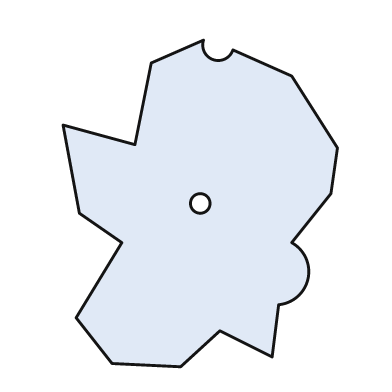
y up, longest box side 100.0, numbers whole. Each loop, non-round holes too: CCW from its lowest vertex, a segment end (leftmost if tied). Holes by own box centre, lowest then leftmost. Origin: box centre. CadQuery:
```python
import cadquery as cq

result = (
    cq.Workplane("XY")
    .moveTo(-6.0, -50.0)
    .lineTo(6.0, -39.0)
    .lineTo(22.0, -47.0)
    .lineTo(24.0, -31.0)
    .threePointArc((33.0, -23.0), (28.0, -12.0))
    .lineTo(40.0, 3.0)
    .lineTo(42.0, 17.0)
    .lineTo(28.0, 39.0)
    .lineTo(10.0, 47.0)
    .threePointArc((4.0, 44.0), (1.0, 50.0))
    .lineTo(-15.0, 43.0)
    .lineTo(-20.0, 18.0)
    .lineTo(-42.0, 24.0)
    .lineTo(-37.0, -3.0)
    .lineTo(-24.0, -12.0)
    .lineTo(-38.0, -35.0)
    .lineTo(-27.0, -49.0)
    .close()
    .moveTo(0.0, 0.0)
    .circle(3.0)
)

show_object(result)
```